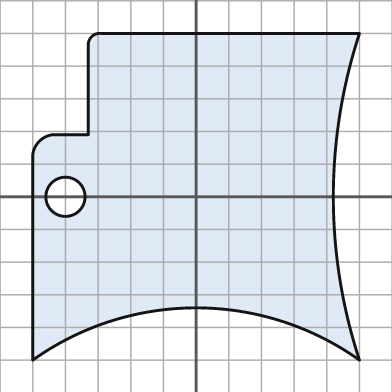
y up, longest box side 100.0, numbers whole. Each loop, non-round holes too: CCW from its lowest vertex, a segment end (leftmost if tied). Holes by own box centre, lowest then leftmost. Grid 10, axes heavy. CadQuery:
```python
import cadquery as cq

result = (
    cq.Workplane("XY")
    .moveTo(-50.0, -50.0)
    .threePointArc((0.0, -34.0), (50.0, -50.0))
    .threePointArc((42.0, 0.0), (50.0, 50.0))
    .lineTo(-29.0, 50.0)
    .threePointArc((-32.0, 49.0), (-33.0, 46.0))
    .lineTo(-33.0, 19.0)
    .lineTo(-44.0, 19.0)
    .threePointArc((-48.0, 17.0), (-50.0, 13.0))
    .close()
    .moveTo(-40.0, 0.0)
    .circle(6.0)
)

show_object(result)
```